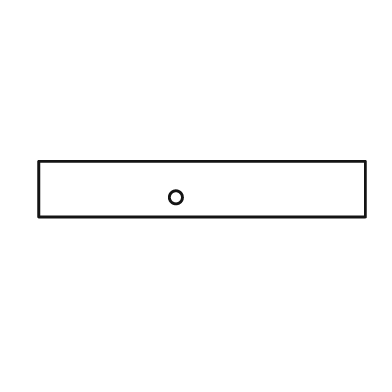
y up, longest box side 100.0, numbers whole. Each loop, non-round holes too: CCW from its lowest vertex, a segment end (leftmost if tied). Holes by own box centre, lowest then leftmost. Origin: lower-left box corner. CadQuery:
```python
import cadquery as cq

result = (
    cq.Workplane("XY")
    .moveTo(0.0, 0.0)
    .lineTo(100.0, 0.0)
    .lineTo(100.0, 17.0)
    .lineTo(0.0, 17.0)
    .close()
    .moveTo(42.0, 6.0)
    .circle(2.0)
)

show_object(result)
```